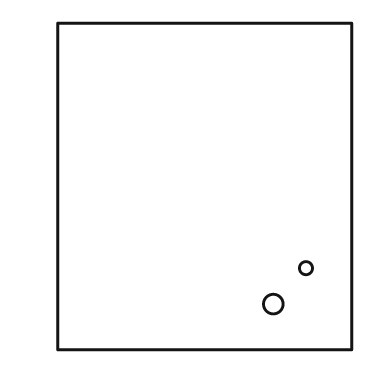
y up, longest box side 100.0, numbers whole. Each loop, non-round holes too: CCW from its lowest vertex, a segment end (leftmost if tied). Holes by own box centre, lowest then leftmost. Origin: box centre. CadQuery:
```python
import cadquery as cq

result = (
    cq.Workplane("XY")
    .moveTo(-45.0, -50.0)
    .lineTo(45.0, -50.0)
    .lineTo(45.0, 50.0)
    .lineTo(-45.0, 50.0)
    .close()
    .moveTo(21.0, -36.0)
    .circle(3.0)
    .moveTo(31.0, -25.0)
    .circle(2.0)
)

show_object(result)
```